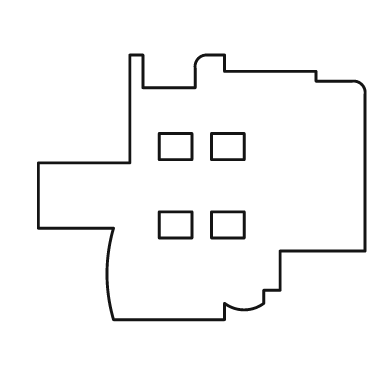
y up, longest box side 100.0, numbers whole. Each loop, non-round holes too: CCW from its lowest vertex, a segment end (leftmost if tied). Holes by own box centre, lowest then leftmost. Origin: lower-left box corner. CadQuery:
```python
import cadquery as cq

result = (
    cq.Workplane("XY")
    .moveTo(23.0, 0.0)
    .lineTo(57.0, 0.0)
    .lineTo(57.0, 5.0)
    .threePointArc((63.0, 3.0), (69.0, 5.0))
    .lineTo(69.0, 9.0)
    .lineTo(74.0, 9.0)
    .lineTo(74.0, 21.0)
    .lineTo(100.0, 21.0)
    .lineTo(100.0, 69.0)
    .threePointArc((99.0, 72.0), (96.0, 73.0))
    .lineTo(85.0, 73.0)
    .lineTo(85.0, 76.0)
    .lineTo(57.0, 76.0)
    .lineTo(57.0, 81.0)
    .lineTo(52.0, 81.0)
    .threePointArc((49.0, 80.0), (48.0, 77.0))
    .lineTo(48.0, 71.0)
    .lineTo(32.0, 71.0)
    .lineTo(32.0, 81.0)
    .lineTo(28.0, 81.0)
    .lineTo(28.0, 48.0)
    .lineTo(0.0, 48.0)
    .lineTo(0.0, 28.0)
    .lineTo(23.0, 28.0)
    .threePointArc((21.0, 14.0), (23.0, 0.0))
    .close()
    .moveTo(37.0, 25.0)
    .lineTo(47.0, 25.0)
    .lineTo(47.0, 33.0)
    .lineTo(37.0, 33.0)
    .close()
    .moveTo(53.0, 25.0)
    .lineTo(63.0, 25.0)
    .lineTo(63.0, 33.0)
    .lineTo(53.0, 33.0)
    .close()
    .moveTo(37.0, 49.0)
    .lineTo(47.0, 49.0)
    .lineTo(47.0, 57.0)
    .lineTo(37.0, 57.0)
    .close()
    .moveTo(53.0, 49.0)
    .lineTo(63.0, 49.0)
    .lineTo(63.0, 57.0)
    .lineTo(53.0, 57.0)
    .close()
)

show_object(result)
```